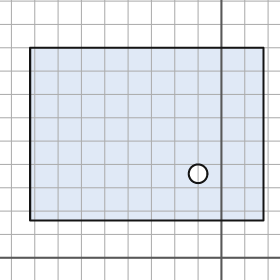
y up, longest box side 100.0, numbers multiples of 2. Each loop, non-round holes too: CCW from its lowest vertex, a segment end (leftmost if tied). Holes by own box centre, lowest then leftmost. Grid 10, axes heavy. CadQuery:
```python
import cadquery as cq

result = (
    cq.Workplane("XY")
    .moveTo(-82.0, 16.0)
    .lineTo(18.0, 16.0)
    .lineTo(18.0, 90.0)
    .lineTo(-82.0, 90.0)
    .close()
    .moveTo(-10.0, 36.0)
    .circle(4.0)
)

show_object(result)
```